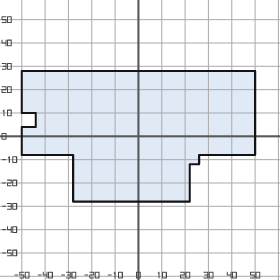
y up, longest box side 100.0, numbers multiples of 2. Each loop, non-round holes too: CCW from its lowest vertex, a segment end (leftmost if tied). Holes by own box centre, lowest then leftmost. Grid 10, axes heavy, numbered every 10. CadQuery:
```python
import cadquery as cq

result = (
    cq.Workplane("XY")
    .moveTo(-28.0, -28.0)
    .lineTo(22.0, -28.0)
    .lineTo(22.0, -12.0)
    .lineTo(26.0, -12.0)
    .lineTo(26.0, -8.0)
    .lineTo(50.0, -8.0)
    .lineTo(50.0, 28.0)
    .lineTo(-50.0, 28.0)
    .lineTo(-50.0, 10.0)
    .lineTo(-44.0, 10.0)
    .lineTo(-44.0, 4.0)
    .lineTo(-50.0, 4.0)
    .lineTo(-50.0, -8.0)
    .lineTo(-28.0, -8.0)
    .close()
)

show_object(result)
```